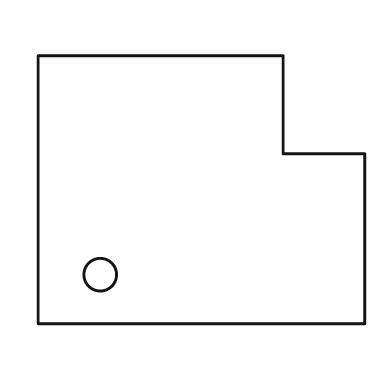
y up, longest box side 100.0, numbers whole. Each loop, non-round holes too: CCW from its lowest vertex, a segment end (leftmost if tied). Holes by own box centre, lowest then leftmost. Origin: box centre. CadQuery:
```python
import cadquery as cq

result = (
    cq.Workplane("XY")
    .moveTo(-50.0, -41.0)
    .lineTo(50.0, -41.0)
    .lineTo(50.0, 11.0)
    .lineTo(25.0, 11.0)
    .lineTo(25.0, 41.0)
    .lineTo(-50.0, 41.0)
    .close()
    .moveTo(-31.0, -26.0)
    .circle(5.0)
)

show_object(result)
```